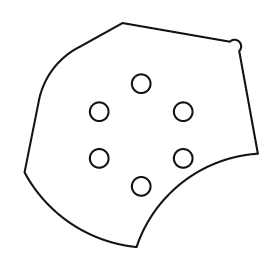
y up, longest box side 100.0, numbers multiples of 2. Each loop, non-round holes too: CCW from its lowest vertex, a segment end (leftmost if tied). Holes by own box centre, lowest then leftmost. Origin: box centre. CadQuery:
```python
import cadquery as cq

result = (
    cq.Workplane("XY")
    .moveTo(-2.0, -48.0)
    .threePointArc((18.0, -20.0), (50.0, -8.0))
    .lineTo(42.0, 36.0)
    .threePointArc((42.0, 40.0), (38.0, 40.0))
    .lineTo(-8.0, 48.0)
    .lineTo(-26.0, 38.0)
    .threePointArc((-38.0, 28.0), (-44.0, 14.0))
    .lineTo(-50.0, -16.0)
    .threePointArc((-30.0, -38.0), (-2.0, -48.0))
    .close()
    .moveTo(0.0, -22.0)
    .circle(4.0)
    .moveTo(-18.0, -10.0)
    .circle(4.0)
    .moveTo(18.0, -10.0)
    .circle(4.0)
    .moveTo(-18.0, 10.0)
    .circle(4.0)
    .moveTo(18.0, 10.0)
    .circle(4.0)
    .moveTo(0.0, 22.0)
    .circle(4.0)
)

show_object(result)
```